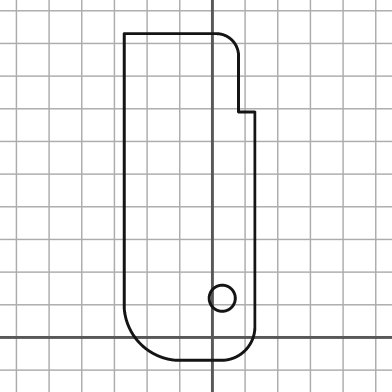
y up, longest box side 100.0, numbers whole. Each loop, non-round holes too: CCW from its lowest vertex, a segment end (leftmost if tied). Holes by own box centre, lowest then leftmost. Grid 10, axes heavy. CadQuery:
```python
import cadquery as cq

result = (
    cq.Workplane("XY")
    .moveTo(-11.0, -7.0)
    .lineTo(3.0, -7.0)
    .threePointArc((10.0, -4.0), (13.0, 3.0))
    .lineTo(13.0, 69.0)
    .lineTo(8.0, 69.0)
    .lineTo(8.0, 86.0)
    .threePointArc((6.0, 91.0), (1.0, 93.0))
    .lineTo(-27.0, 93.0)
    .lineTo(-27.0, 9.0)
    .threePointArc((-22.0, -2.0), (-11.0, -7.0))
    .close()
    .moveTo(3.0, 12.0)
    .circle(4.0)
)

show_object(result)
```